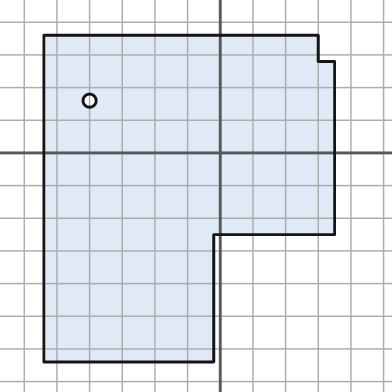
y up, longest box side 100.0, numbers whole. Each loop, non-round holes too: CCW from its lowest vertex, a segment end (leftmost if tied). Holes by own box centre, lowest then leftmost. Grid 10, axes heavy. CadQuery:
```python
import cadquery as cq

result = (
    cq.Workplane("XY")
    .moveTo(-54.0, -64.0)
    .lineTo(-2.0, -64.0)
    .lineTo(-2.0, -25.0)
    .lineTo(35.0, -25.0)
    .lineTo(35.0, 28.0)
    .lineTo(30.0, 28.0)
    .lineTo(30.0, 36.0)
    .lineTo(-54.0, 36.0)
    .close()
    .moveTo(-40.0, 16.0)
    .circle(2.0)
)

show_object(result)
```